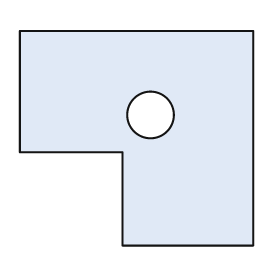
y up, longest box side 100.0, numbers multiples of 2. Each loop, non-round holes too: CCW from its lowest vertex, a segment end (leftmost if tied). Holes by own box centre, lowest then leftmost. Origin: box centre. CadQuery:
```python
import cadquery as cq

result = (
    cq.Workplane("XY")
    .moveTo(-6.0, -46.0)
    .lineTo(50.0, -46.0)
    .lineTo(50.0, 46.0)
    .lineTo(-50.0, 46.0)
    .lineTo(-50.0, -6.0)
    .lineTo(-6.0, -6.0)
    .close()
    .moveTo(6.0, 10.0)
    .circle(10.0)
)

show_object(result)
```